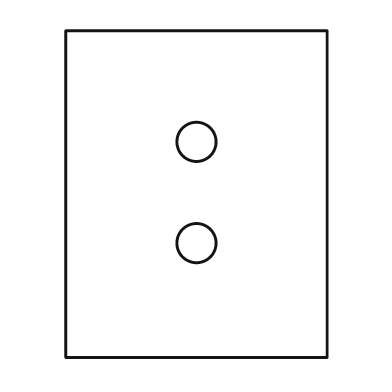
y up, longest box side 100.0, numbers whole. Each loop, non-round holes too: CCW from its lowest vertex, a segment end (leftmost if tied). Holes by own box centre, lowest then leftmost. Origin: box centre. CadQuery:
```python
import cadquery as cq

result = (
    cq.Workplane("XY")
    .moveTo(-40.0, -50.0)
    .lineTo(40.0, -50.0)
    .lineTo(40.0, 50.0)
    .lineTo(-40.0, 50.0)
    .close()
    .moveTo(0.0, -15.0)
    .circle(6.0)
    .moveTo(0.0, 16.0)
    .circle(6.0)
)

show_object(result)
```